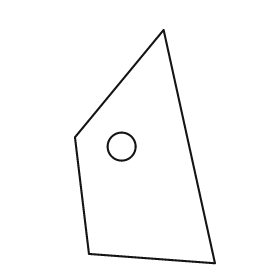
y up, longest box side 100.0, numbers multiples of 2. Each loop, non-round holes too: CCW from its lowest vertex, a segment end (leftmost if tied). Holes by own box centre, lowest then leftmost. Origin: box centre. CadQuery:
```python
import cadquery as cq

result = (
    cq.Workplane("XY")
    .moveTo(30.0, -50.0)
    .lineTo(8.0, 50.0)
    .lineTo(-30.0, 4.0)
    .lineTo(-24.0, -46.0)
    .close()
    .moveTo(-10.0, 0.0)
    .circle(6.0)
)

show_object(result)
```